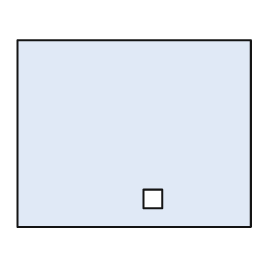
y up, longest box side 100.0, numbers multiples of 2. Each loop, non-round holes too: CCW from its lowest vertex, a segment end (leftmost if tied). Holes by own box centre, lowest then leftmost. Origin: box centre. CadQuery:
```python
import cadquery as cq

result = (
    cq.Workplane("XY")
    .moveTo(-50.0, -40.0)
    .lineTo(50.0, -40.0)
    .lineTo(50.0, 40.0)
    .lineTo(-50.0, 40.0)
    .close()
    .moveTo(4.0, -32.0)
    .lineTo(12.0, -32.0)
    .lineTo(12.0, -24.0)
    .lineTo(4.0, -24.0)
    .close()
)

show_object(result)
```